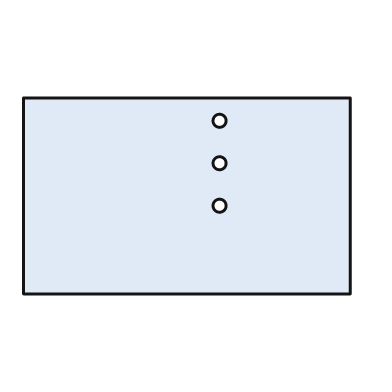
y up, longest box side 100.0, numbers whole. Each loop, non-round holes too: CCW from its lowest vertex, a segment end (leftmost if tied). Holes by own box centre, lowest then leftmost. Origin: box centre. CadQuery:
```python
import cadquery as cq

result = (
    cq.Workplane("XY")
    .moveTo(-50.0, -30.0)
    .lineTo(50.0, -30.0)
    .lineTo(50.0, 30.0)
    .lineTo(-50.0, 30.0)
    .close()
    .moveTo(10.0, -3.0)
    .circle(2.0)
    .moveTo(10.0, 10.0)
    .circle(2.0)
    .moveTo(10.0, 23.0)
    .circle(2.0)
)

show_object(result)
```